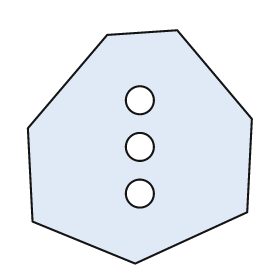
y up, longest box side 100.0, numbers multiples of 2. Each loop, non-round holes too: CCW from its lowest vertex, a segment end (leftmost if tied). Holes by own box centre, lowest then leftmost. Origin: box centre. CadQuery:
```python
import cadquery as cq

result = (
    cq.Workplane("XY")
    .moveTo(-2.0, -50.0)
    .lineTo(46.0, -28.0)
    .lineTo(48.0, 12.0)
    .lineTo(16.0, 50.0)
    .lineTo(-14.0, 48.0)
    .lineTo(-48.0, 8.0)
    .lineTo(-46.0, -32.0)
    .close()
    .moveTo(0.0, -20.0)
    .circle(6.0)
    .moveTo(0.0, 0.0)
    .circle(6.0)
    .moveTo(0.0, 20.0)
    .circle(6.0)
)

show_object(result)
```